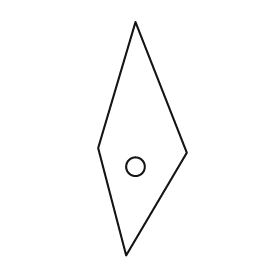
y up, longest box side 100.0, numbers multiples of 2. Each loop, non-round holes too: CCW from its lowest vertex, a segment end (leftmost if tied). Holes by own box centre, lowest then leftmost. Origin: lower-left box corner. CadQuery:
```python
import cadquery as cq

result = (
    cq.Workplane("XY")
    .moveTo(12.0, 0.0)
    .lineTo(38.0, 44.0)
    .lineTo(16.0, 100.0)
    .lineTo(0.0, 46.0)
    .close()
    .moveTo(16.0, 38.0)
    .circle(4.0)
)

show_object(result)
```